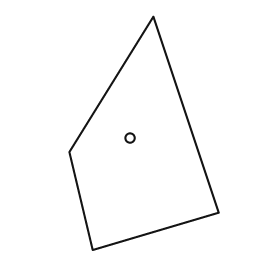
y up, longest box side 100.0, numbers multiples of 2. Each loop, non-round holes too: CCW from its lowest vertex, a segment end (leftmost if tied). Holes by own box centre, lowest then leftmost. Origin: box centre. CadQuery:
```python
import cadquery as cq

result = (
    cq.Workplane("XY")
    .moveTo(-22.0, -50.0)
    .lineTo(32.0, -34.0)
    .lineTo(4.0, 50.0)
    .lineTo(-32.0, -8.0)
    .close()
    .moveTo(-6.0, -2.0)
    .circle(2.0)
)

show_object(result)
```